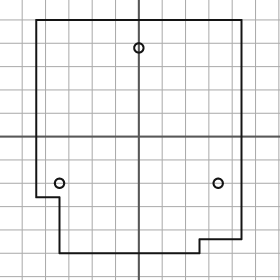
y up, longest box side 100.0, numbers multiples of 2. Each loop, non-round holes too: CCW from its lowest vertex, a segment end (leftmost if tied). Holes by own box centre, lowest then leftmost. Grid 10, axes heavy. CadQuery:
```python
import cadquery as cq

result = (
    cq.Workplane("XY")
    .moveTo(-34.0, -50.0)
    .lineTo(26.0, -50.0)
    .lineTo(26.0, -44.0)
    .lineTo(44.0, -44.0)
    .lineTo(44.0, 50.0)
    .lineTo(-44.0, 50.0)
    .lineTo(-44.0, -26.0)
    .lineTo(-34.0, -26.0)
    .close()
    .moveTo(-34.0, -20.0)
    .circle(2.0)
    .moveTo(34.0, -20.0)
    .circle(2.0)
    .moveTo(0.0, 38.0)
    .circle(2.0)
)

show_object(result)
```